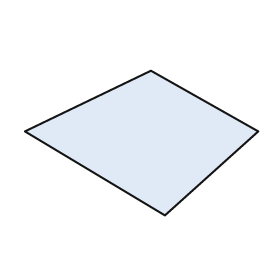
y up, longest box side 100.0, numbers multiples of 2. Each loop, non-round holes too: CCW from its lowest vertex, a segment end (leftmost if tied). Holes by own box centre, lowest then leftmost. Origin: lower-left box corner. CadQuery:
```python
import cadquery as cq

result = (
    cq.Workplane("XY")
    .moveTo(60.0, 0.0)
    .lineTo(100.0, 36.0)
    .lineTo(54.0, 62.0)
    .lineTo(0.0, 36.0)
    .close()
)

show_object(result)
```